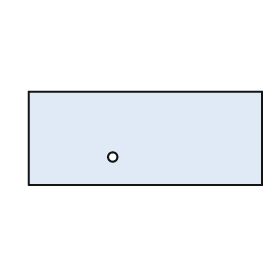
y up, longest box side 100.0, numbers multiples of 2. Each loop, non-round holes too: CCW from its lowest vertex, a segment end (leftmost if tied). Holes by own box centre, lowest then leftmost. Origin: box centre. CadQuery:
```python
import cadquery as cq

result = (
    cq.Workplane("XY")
    .moveTo(-50.0, -20.0)
    .lineTo(50.0, -20.0)
    .lineTo(50.0, 20.0)
    .lineTo(-50.0, 20.0)
    .close()
    .moveTo(-14.0, -8.0)
    .circle(2.0)
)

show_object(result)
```